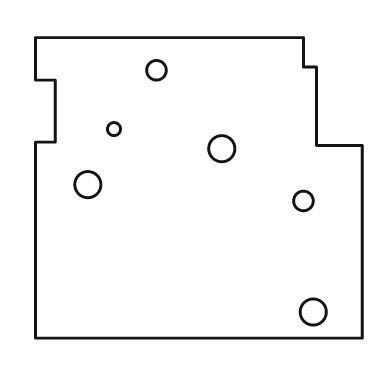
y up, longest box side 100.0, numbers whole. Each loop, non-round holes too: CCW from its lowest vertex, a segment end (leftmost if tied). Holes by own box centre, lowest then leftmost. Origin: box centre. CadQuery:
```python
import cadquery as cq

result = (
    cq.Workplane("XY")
    .moveTo(-50.0, -46.0)
    .lineTo(50.0, -46.0)
    .lineTo(50.0, 13.0)
    .lineTo(36.0, 13.0)
    .lineTo(36.0, 37.0)
    .lineTo(32.0, 37.0)
    .lineTo(32.0, 46.0)
    .lineTo(-50.0, 46.0)
    .lineTo(-50.0, 33.0)
    .lineTo(-44.0, 33.0)
    .lineTo(-44.0, 14.0)
    .lineTo(-50.0, 14.0)
    .close()
    .moveTo(35.0, -38.0)
    .circle(4.0)
    .moveTo(32.0, -4.0)
    .circle(3.0)
    .moveTo(-34.0, 1.0)
    .circle(4.0)
    .moveTo(7.0, 12.0)
    .circle(4.0)
    .moveTo(-26.0, 18.0)
    .circle(2.0)
    .moveTo(-13.0, 36.0)
    .circle(3.0)
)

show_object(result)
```